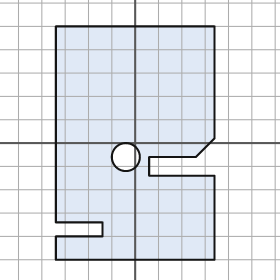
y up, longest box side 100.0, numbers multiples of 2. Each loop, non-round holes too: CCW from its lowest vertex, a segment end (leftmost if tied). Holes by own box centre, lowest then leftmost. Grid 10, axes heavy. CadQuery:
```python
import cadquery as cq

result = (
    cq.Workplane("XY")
    .moveTo(-34.0, -50.0)
    .lineTo(34.0, -50.0)
    .lineTo(34.0, -14.0)
    .lineTo(6.0, -14.0)
    .lineTo(6.0, -6.0)
    .lineTo(26.0, -6.0)
    .lineTo(34.0, 2.0)
    .lineTo(34.0, 50.0)
    .lineTo(-34.0, 50.0)
    .lineTo(-34.0, -34.0)
    .lineTo(-14.0, -34.0)
    .lineTo(-14.0, -40.0)
    .lineTo(-34.0, -40.0)
    .close()
    .moveTo(-4.0, -6.0)
    .circle(6.0)
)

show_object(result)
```